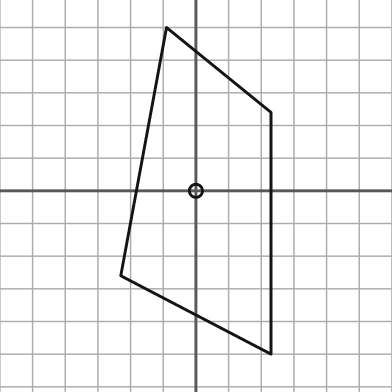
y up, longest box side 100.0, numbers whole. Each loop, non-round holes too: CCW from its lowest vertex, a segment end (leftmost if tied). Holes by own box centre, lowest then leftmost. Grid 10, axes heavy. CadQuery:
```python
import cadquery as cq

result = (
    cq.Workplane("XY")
    .moveTo(23.0, -50.0)
    .lineTo(23.0, 24.0)
    .lineTo(-9.0, 50.0)
    .lineTo(-23.0, -26.0)
    .close()
    .moveTo(0.0, 0.0)
    .circle(2.0)
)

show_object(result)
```